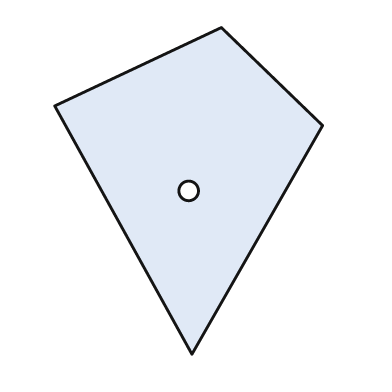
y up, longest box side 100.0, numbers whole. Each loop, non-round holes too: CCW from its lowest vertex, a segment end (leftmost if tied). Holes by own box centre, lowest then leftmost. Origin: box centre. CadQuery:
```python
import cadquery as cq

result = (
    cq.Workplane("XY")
    .moveTo(1.0, -50.0)
    .lineTo(41.0, 20.0)
    .lineTo(10.0, 50.0)
    .lineTo(-41.0, 26.0)
    .close()
    .moveTo(0.0, 0.0)
    .circle(3.0)
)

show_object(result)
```